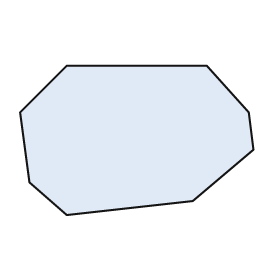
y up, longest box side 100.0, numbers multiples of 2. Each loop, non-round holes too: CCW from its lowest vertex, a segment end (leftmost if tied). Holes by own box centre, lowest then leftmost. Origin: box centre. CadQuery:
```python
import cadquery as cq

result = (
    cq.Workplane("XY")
    .moveTo(-30.0, -32.0)
    .lineTo(24.0, -26.0)
    .lineTo(50.0, -4.0)
    .lineTo(48.0, 12.0)
    .lineTo(30.0, 32.0)
    .lineTo(-30.0, 32.0)
    .lineTo(-50.0, 12.0)
    .lineTo(-46.0, -18.0)
    .close()
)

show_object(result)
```